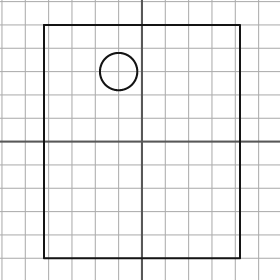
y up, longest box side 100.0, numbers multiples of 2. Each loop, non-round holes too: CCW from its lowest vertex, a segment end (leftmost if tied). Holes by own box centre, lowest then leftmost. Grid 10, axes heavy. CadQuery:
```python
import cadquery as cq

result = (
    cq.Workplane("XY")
    .moveTo(-42.0, -50.0)
    .lineTo(42.0, -50.0)
    .lineTo(42.0, 50.0)
    .lineTo(-42.0, 50.0)
    .close()
    .moveTo(-10.0, 30.0)
    .circle(8.0)
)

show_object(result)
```